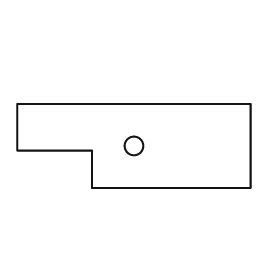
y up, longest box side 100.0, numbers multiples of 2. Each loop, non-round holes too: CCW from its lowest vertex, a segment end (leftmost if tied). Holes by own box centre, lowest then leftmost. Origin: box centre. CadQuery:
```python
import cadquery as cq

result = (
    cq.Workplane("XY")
    .moveTo(-18.0, -18.0)
    .lineTo(50.0, -18.0)
    .lineTo(50.0, 18.0)
    .lineTo(-50.0, 18.0)
    .lineTo(-50.0, -2.0)
    .lineTo(-18.0, -2.0)
    .close()
    .moveTo(0.0, 0.0)
    .circle(4.0)
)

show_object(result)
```